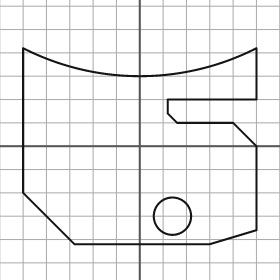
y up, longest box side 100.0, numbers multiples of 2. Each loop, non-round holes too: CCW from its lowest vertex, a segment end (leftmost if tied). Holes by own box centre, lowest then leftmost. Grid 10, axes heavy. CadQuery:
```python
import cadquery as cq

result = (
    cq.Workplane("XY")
    .moveTo(-28.0, -42.0)
    .lineTo(30.0, -42.0)
    .lineTo(50.0, -36.0)
    .lineTo(50.0, 0.0)
    .lineTo(40.0, 10.0)
    .lineTo(16.0, 10.0)
    .lineTo(12.0, 14.0)
    .lineTo(12.0, 20.0)
    .lineTo(50.0, 20.0)
    .lineTo(50.0, 42.0)
    .threePointArc((0.0, 30.0), (-50.0, 42.0))
    .lineTo(-50.0, -20.0)
    .close()
    .moveTo(14.0, -30.0)
    .circle(8.0)
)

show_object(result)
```